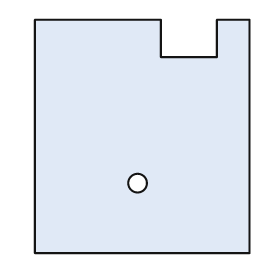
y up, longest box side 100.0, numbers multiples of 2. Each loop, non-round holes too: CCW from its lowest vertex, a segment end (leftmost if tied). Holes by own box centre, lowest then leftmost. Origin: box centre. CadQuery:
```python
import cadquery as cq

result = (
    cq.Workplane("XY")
    .moveTo(-46.0, -50.0)
    .lineTo(46.0, -50.0)
    .lineTo(46.0, 50.0)
    .lineTo(32.0, 50.0)
    .lineTo(32.0, 34.0)
    .lineTo(8.0, 34.0)
    .lineTo(8.0, 50.0)
    .lineTo(-46.0, 50.0)
    .close()
    .moveTo(-2.0, -20.0)
    .circle(4.0)
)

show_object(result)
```